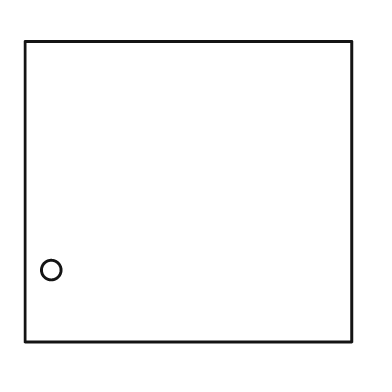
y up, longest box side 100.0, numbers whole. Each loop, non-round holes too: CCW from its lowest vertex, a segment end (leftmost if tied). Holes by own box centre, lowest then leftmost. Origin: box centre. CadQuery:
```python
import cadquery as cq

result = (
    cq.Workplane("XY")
    .moveTo(-50.0, -46.0)
    .lineTo(50.0, -46.0)
    .lineTo(50.0, 46.0)
    .lineTo(-50.0, 46.0)
    .close()
    .moveTo(-42.0, -24.0)
    .circle(3.0)
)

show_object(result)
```